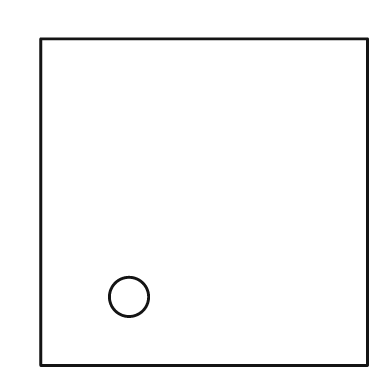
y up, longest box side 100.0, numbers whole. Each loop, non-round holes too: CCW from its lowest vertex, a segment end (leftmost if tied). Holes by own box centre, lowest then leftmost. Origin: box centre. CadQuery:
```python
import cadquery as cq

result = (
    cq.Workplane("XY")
    .moveTo(-50.0, -50.0)
    .lineTo(50.0, -50.0)
    .lineTo(50.0, 50.0)
    .lineTo(-50.0, 50.0)
    .close()
    .moveTo(-23.0, -29.0)
    .circle(6.0)
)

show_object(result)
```